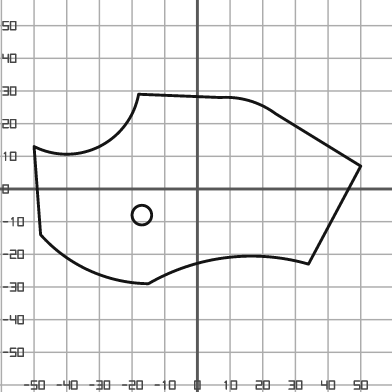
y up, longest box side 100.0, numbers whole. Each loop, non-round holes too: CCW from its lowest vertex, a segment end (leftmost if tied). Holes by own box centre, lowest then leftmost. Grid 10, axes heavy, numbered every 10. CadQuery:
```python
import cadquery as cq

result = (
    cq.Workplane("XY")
    .moveTo(-15.0, -29.0)
    .threePointArc((9.0, -21.0), (34.0, -23.0))
    .lineTo(50.0, 7.0)
    .lineTo(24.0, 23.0)
    .threePointArc((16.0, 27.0), (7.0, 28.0))
    .lineTo(-18.0, 29.0)
    .threePointArc((-30.0, 13.0), (-50.0, 13.0))
    .lineTo(-48.0, -14.0)
    .threePointArc((-33.0, -25.0), (-15.0, -29.0))
    .close()
    .moveTo(-17.0, -8.0)
    .circle(3.0)
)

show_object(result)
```